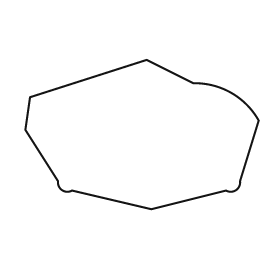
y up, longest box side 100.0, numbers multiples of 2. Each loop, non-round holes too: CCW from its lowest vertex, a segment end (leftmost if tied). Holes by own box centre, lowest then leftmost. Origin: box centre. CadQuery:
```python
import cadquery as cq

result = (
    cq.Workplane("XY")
    .moveTo(4.0, -32.0)
    .lineTo(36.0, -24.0)
    .threePointArc((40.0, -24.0), (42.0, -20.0))
    .lineTo(50.0, 6.0)
    .threePointArc((38.0, 18.0), (22.0, 22.0))
    .lineTo(2.0, 32.0)
    .lineTo(-48.0, 16.0)
    .lineTo(-50.0, 2.0)
    .lineTo(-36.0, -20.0)
    .threePointArc((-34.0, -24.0), (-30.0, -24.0))
    .close()
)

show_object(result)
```